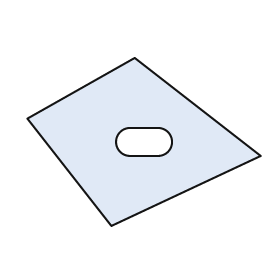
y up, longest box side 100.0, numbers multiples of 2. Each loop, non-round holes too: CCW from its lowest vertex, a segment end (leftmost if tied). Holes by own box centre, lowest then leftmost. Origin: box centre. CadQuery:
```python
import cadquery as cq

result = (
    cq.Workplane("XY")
    .moveTo(-14.0, -36.0)
    .lineTo(50.0, -6.0)
    .lineTo(-4.0, 36.0)
    .lineTo(-50.0, 10.0)
    .close()
    .moveTo(-6.0, -6.0)
    .lineTo(6.0, -6.0)
    .threePointArc((12.0, 0.0), (6.0, 6.0))
    .lineTo(-6.0, 6.0)
    .threePointArc((-12.0, 0.0), (-6.0, -6.0))
    .close()
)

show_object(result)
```